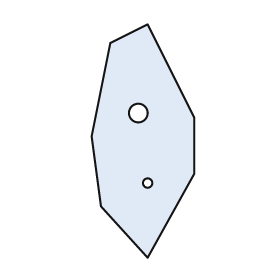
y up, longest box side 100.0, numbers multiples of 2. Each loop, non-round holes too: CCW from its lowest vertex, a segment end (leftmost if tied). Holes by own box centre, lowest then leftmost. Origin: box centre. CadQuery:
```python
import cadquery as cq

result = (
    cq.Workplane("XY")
    .moveTo(2.0, -50.0)
    .lineTo(22.0, -14.0)
    .lineTo(22.0, 10.0)
    .lineTo(2.0, 50.0)
    .lineTo(-14.0, 42.0)
    .lineTo(-22.0, 2.0)
    .lineTo(-18.0, -28.0)
    .close()
    .moveTo(2.0, -18.0)
    .circle(2.0)
    .moveTo(-2.0, 12.0)
    .circle(4.0)
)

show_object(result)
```